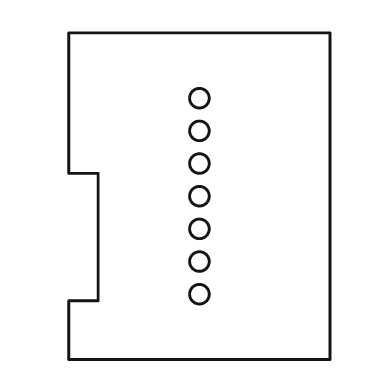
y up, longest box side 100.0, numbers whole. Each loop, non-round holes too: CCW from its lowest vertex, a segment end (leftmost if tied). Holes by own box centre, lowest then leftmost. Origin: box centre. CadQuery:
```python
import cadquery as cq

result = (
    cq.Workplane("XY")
    .moveTo(-40.0, -50.0)
    .lineTo(40.0, -50.0)
    .lineTo(40.0, 50.0)
    .lineTo(-40.0, 50.0)
    .lineTo(-40.0, 7.0)
    .lineTo(-31.0, 7.0)
    .lineTo(-31.0, -32.0)
    .lineTo(-40.0, -32.0)
    .close()
    .moveTo(0.0, -30.0)
    .circle(3.0)
    .moveTo(0.0, -20.0)
    .circle(3.0)
    .moveTo(0.0, -10.0)
    .circle(3.0)
    .moveTo(0.0, 0.0)
    .circle(3.0)
    .moveTo(0.0, 10.0)
    .circle(3.0)
    .moveTo(0.0, 20.0)
    .circle(3.0)
    .moveTo(0.0, 30.0)
    .circle(3.0)
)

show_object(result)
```